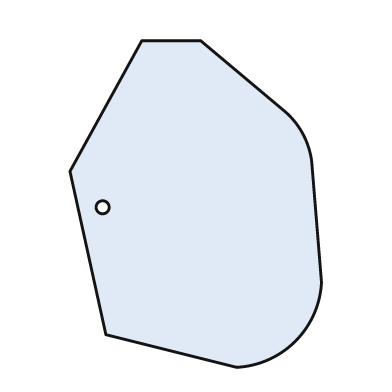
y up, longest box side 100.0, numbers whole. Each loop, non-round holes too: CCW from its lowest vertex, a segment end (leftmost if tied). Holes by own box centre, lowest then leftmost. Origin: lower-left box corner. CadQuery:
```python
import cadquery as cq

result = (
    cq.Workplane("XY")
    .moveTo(51.0, 0.0)
    .threePointArc((69.0, 8.0), (77.0, 26.0))
    .lineTo(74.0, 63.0)
    .threePointArc((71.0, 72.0), (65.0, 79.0))
    .lineTo(40.0, 100.0)
    .lineTo(22.0, 100.0)
    .lineTo(0.0, 60.0)
    .lineTo(11.0, 10.0)
    .close()
    .moveTo(10.0, 49.0)
    .circle(2.0)
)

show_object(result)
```